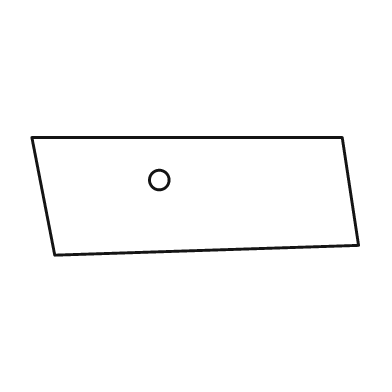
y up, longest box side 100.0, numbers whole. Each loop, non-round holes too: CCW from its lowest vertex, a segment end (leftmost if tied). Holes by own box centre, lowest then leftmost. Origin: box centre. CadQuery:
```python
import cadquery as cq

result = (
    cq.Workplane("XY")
    .moveTo(-43.0, -18.0)
    .lineTo(50.0, -15.0)
    .lineTo(45.0, 18.0)
    .lineTo(-50.0, 18.0)
    .close()
    .moveTo(-11.0, 5.0)
    .circle(3.0)
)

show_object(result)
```